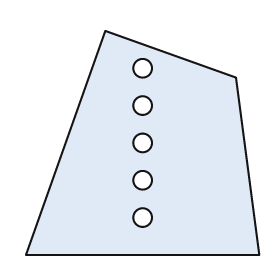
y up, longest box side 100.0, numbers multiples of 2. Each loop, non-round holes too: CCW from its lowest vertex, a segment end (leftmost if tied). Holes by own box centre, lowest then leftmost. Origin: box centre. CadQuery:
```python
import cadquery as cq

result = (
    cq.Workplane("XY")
    .moveTo(-50.0, -48.0)
    .lineTo(50.0, -48.0)
    .lineTo(40.0, 28.0)
    .lineTo(-16.0, 48.0)
    .close()
    .moveTo(0.0, -32.0)
    .circle(4.0)
    .moveTo(0.0, -16.0)
    .circle(4.0)
    .moveTo(0.0, 0.0)
    .circle(4.0)
    .moveTo(0.0, 16.0)
    .circle(4.0)
    .moveTo(0.0, 32.0)
    .circle(4.0)
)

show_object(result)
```